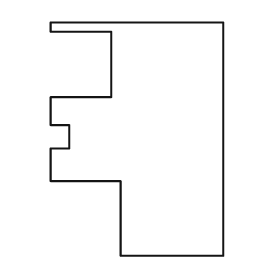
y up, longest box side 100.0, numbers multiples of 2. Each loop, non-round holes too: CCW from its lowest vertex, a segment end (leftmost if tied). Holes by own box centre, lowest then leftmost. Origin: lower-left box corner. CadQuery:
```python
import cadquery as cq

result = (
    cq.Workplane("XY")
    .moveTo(30.0, 0.0)
    .lineTo(74.0, 0.0)
    .lineTo(74.0, 100.0)
    .lineTo(0.0, 100.0)
    .lineTo(0.0, 96.0)
    .lineTo(26.0, 96.0)
    .lineTo(26.0, 68.0)
    .lineTo(0.0, 68.0)
    .lineTo(0.0, 56.0)
    .lineTo(8.0, 56.0)
    .lineTo(8.0, 46.0)
    .lineTo(0.0, 46.0)
    .lineTo(0.0, 32.0)
    .lineTo(30.0, 32.0)
    .close()
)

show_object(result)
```